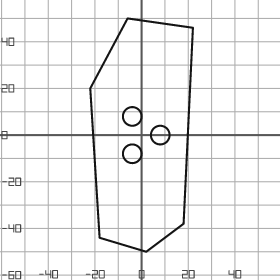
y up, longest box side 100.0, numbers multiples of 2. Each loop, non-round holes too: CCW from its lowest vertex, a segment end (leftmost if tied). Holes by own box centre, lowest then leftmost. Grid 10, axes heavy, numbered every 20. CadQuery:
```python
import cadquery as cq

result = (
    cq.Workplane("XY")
    .moveTo(2.0, -50.0)
    .lineTo(18.0, -38.0)
    .lineTo(22.0, 46.0)
    .lineTo(-6.0, 50.0)
    .lineTo(-22.0, 20.0)
    .lineTo(-18.0, -44.0)
    .close()
    .moveTo(-4.0, -8.0)
    .circle(4.0)
    .moveTo(8.0, 0.0)
    .circle(4.0)
    .moveTo(-4.0, 8.0)
    .circle(4.0)
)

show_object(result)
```